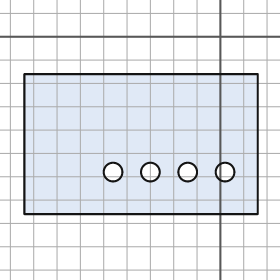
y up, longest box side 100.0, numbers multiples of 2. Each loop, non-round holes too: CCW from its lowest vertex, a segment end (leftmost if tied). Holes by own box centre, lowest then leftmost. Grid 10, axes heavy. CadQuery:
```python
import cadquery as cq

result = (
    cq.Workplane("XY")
    .moveTo(-84.0, -76.0)
    .lineTo(16.0, -76.0)
    .lineTo(16.0, -16.0)
    .lineTo(-84.0, -16.0)
    .close()
    .moveTo(-46.0, -58.0)
    .circle(4.0)
    .moveTo(-30.0, -58.0)
    .circle(4.0)
    .moveTo(-14.0, -58.0)
    .circle(4.0)
    .moveTo(2.0, -58.0)
    .circle(4.0)
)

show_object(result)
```